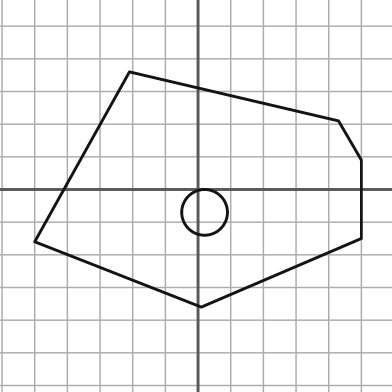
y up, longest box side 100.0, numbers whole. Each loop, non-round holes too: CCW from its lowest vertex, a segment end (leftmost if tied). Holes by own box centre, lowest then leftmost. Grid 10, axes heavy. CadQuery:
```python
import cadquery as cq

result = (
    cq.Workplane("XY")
    .moveTo(1.0, -36.0)
    .lineTo(50.0, -15.0)
    .lineTo(50.0, 9.0)
    .lineTo(43.0, 21.0)
    .lineTo(-21.0, 36.0)
    .lineTo(-50.0, -16.0)
    .close()
    .moveTo(2.0, -7.0)
    .circle(7.0)
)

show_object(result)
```